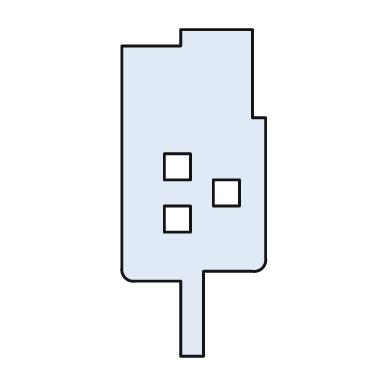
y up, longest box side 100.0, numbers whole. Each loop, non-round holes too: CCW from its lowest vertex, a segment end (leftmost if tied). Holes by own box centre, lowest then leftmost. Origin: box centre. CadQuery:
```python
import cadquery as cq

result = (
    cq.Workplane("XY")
    .moveTo(-4.0, -50.0)
    .lineTo(3.0, -50.0)
    .lineTo(3.0, -24.0)
    .lineTo(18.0, -24.0)
    .threePointArc((21.0, -23.0), (22.0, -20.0))
    .lineTo(22.0, 23.0)
    .lineTo(18.0, 23.0)
    .lineTo(18.0, 50.0)
    .lineTo(-4.0, 50.0)
    .lineTo(-4.0, 45.0)
    .lineTo(-22.0, 45.0)
    .lineTo(-22.0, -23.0)
    .threePointArc((-21.0, -26.0), (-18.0, -27.0))
    .lineTo(-4.0, -27.0)
    .close()
    .moveTo(-9.0, -12.0)
    .lineTo(-1.0, -12.0)
    .lineTo(-1.0, -4.0)
    .lineTo(-9.0, -4.0)
    .close()
    .moveTo(6.0, -4.0)
    .lineTo(14.0, -4.0)
    .lineTo(14.0, 4.0)
    .lineTo(6.0, 4.0)
    .close()
    .moveTo(-9.0, 4.0)
    .lineTo(-1.0, 4.0)
    .lineTo(-1.0, 12.0)
    .lineTo(-9.0, 12.0)
    .close()
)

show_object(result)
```